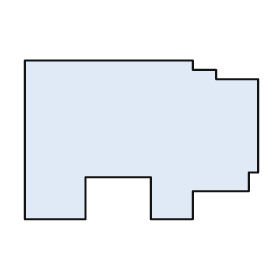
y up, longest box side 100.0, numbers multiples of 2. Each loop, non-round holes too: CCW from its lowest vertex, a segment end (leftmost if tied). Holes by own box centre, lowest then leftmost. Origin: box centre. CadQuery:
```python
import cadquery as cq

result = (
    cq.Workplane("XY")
    .moveTo(-50.0, -34.0)
    .lineTo(-24.0, -34.0)
    .lineTo(-24.0, -16.0)
    .lineTo(4.0, -16.0)
    .lineTo(4.0, -34.0)
    .lineTo(22.0, -34.0)
    .lineTo(22.0, -22.0)
    .lineTo(46.0, -22.0)
    .lineTo(46.0, -14.0)
    .lineTo(50.0, -14.0)
    .lineTo(50.0, 26.0)
    .lineTo(32.0, 26.0)
    .lineTo(32.0, 30.0)
    .lineTo(22.0, 30.0)
    .lineTo(22.0, 34.0)
    .lineTo(-50.0, 34.0)
    .close()
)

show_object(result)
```